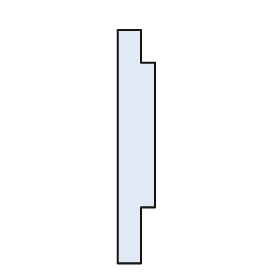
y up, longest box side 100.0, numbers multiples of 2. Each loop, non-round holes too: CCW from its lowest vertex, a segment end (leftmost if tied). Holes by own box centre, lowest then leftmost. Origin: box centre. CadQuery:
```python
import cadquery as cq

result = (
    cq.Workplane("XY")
    .moveTo(-8.0, -50.0)
    .lineTo(2.0, -50.0)
    .lineTo(2.0, -26.0)
    .lineTo(8.0, -26.0)
    .lineTo(8.0, 36.0)
    .lineTo(2.0, 36.0)
    .lineTo(2.0, 50.0)
    .lineTo(-8.0, 50.0)
    .close()
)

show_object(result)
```